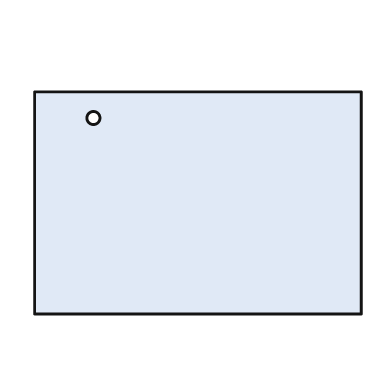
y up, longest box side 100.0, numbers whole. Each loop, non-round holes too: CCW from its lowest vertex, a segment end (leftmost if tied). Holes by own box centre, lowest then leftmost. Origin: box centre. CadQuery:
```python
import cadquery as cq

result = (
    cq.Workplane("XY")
    .moveTo(-50.0, -34.0)
    .lineTo(50.0, -34.0)
    .lineTo(50.0, 34.0)
    .lineTo(-50.0, 34.0)
    .close()
    .moveTo(-32.0, 26.0)
    .circle(2.0)
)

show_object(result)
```